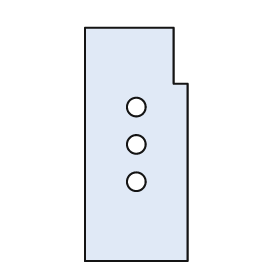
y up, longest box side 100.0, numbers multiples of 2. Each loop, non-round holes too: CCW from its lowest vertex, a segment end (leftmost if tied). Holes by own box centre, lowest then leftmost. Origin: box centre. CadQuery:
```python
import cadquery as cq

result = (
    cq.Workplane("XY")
    .moveTo(-22.0, -50.0)
    .lineTo(22.0, -50.0)
    .lineTo(22.0, 26.0)
    .lineTo(16.0, 26.0)
    .lineTo(16.0, 50.0)
    .lineTo(-22.0, 50.0)
    .close()
    .moveTo(0.0, -16.0)
    .circle(4.0)
    .moveTo(0.0, 0.0)
    .circle(4.0)
    .moveTo(0.0, 16.0)
    .circle(4.0)
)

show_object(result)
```